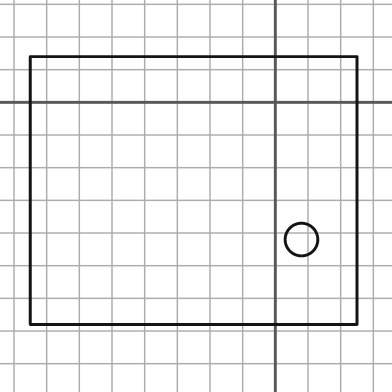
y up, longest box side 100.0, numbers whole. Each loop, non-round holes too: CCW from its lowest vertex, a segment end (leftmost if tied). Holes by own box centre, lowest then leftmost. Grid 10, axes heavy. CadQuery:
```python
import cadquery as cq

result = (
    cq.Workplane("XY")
    .moveTo(-75.0, -68.0)
    .lineTo(25.0, -68.0)
    .lineTo(25.0, 14.0)
    .lineTo(-75.0, 14.0)
    .close()
    .moveTo(8.0, -42.0)
    .circle(5.0)
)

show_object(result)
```